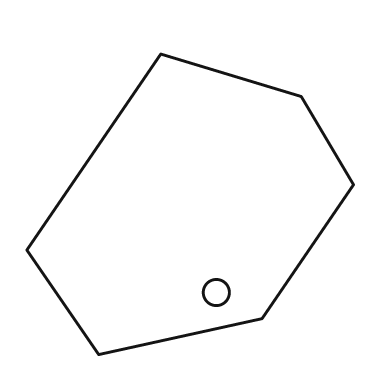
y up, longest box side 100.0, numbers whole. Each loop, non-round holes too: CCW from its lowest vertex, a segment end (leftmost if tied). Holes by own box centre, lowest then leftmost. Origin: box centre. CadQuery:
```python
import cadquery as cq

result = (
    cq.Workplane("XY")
    .moveTo(-28.0, -46.0)
    .lineTo(22.0, -35.0)
    .lineTo(50.0, 6.0)
    .lineTo(34.0, 33.0)
    .lineTo(-9.0, 46.0)
    .lineTo(-50.0, -14.0)
    .close()
    .moveTo(8.0, -27.0)
    .circle(4.0)
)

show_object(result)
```